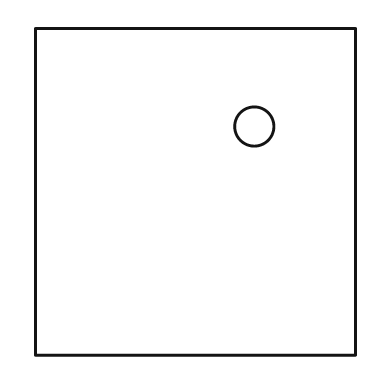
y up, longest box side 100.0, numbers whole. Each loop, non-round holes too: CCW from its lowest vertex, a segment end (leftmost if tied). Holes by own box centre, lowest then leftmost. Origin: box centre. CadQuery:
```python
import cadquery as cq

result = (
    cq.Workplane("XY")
    .moveTo(-49.0, -50.0)
    .lineTo(49.0, -50.0)
    .lineTo(49.0, 50.0)
    .lineTo(-49.0, 50.0)
    .close()
    .moveTo(18.0, 20.0)
    .circle(6.0)
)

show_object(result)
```